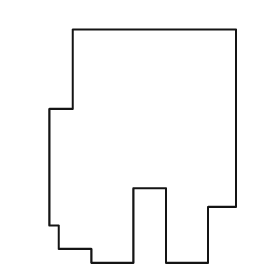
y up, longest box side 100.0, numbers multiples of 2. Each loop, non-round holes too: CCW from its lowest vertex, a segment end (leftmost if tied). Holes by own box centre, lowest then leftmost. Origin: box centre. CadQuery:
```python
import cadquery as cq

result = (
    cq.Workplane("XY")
    .moveTo(-22.0, -50.0)
    .lineTo(-4.0, -50.0)
    .lineTo(-4.0, -18.0)
    .lineTo(10.0, -18.0)
    .lineTo(10.0, -50.0)
    .lineTo(28.0, -50.0)
    .lineTo(28.0, -26.0)
    .lineTo(40.0, -26.0)
    .lineTo(40.0, 50.0)
    .lineTo(-30.0, 50.0)
    .lineTo(-30.0, 16.0)
    .lineTo(-40.0, 16.0)
    .lineTo(-40.0, -34.0)
    .lineTo(-36.0, -34.0)
    .lineTo(-36.0, -44.0)
    .lineTo(-22.0, -44.0)
    .close()
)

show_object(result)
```